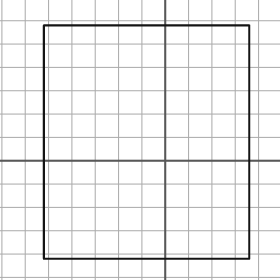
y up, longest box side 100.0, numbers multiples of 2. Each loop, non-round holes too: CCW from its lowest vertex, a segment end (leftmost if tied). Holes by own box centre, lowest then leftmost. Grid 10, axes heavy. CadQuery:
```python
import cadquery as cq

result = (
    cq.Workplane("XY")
    .moveTo(-52.0, -42.0)
    .lineTo(36.0, -42.0)
    .lineTo(36.0, 58.0)
    .lineTo(-52.0, 58.0)
    .close()
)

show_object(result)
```